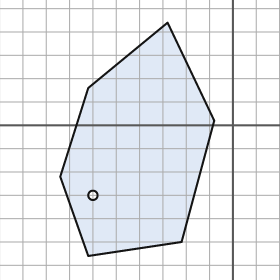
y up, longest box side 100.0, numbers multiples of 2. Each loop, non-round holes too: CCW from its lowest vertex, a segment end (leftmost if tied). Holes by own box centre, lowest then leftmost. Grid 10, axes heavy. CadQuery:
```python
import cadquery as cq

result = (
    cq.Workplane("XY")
    .moveTo(-62.0, -56.0)
    .lineTo(-22.0, -50.0)
    .lineTo(-8.0, 2.0)
    .lineTo(-28.0, 44.0)
    .lineTo(-62.0, 16.0)
    .lineTo(-74.0, -22.0)
    .close()
    .moveTo(-60.0, -30.0)
    .circle(2.0)
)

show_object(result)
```